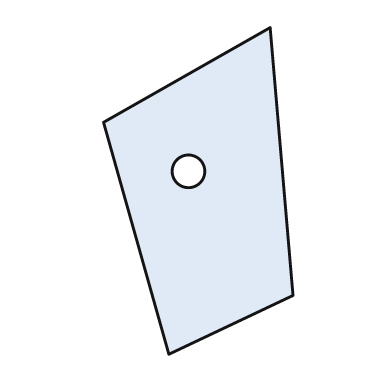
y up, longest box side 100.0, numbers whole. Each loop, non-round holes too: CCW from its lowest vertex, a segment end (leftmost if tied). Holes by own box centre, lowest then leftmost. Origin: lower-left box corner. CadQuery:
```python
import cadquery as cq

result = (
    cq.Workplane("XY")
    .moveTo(20.0, 0.0)
    .lineTo(58.0, 18.0)
    .lineTo(51.0, 100.0)
    .lineTo(0.0, 71.0)
    .close()
    .moveTo(26.0, 56.0)
    .circle(5.0)
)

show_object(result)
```